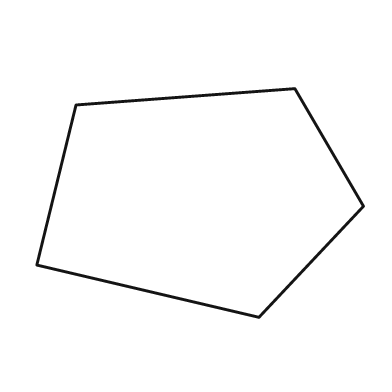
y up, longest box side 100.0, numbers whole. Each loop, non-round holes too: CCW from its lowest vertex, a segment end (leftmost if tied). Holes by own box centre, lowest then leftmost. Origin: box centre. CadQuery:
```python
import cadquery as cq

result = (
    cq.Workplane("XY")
    .moveTo(18.0, -35.0)
    .lineTo(50.0, -1.0)
    .lineTo(29.0, 35.0)
    .lineTo(-38.0, 30.0)
    .lineTo(-50.0, -19.0)
    .close()
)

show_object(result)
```